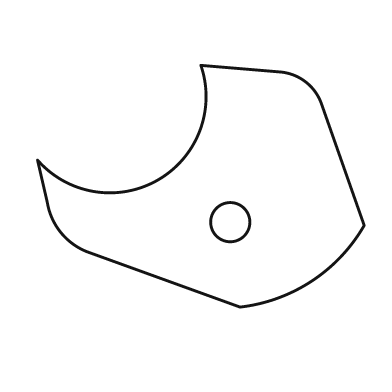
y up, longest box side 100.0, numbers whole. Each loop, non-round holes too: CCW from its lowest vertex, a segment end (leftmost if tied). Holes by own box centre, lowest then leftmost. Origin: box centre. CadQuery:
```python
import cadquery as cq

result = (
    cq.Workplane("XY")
    .moveTo(12.0, -37.0)
    .threePointArc((34.0, -29.0), (50.0, -12.0))
    .lineTo(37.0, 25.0)
    .threePointArc((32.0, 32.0), (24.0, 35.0))
    .lineTo(0.0, 37.0)
    .threePointArc((-13.0, 2.0), (-50.0, 8.0))
    .lineTo(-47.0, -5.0)
    .threePointArc((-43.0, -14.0), (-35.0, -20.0))
    .close()
    .moveTo(9.0, -11.0)
    .circle(6.0)
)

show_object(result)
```